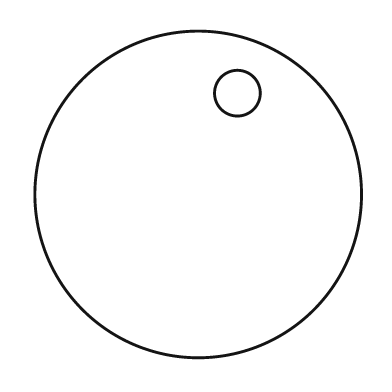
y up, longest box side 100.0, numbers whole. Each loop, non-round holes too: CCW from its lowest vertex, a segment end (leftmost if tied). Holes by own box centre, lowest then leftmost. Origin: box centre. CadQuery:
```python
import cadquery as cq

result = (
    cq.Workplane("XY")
    .moveTo(0.0, 0.0)
    .circle(50.0)
    .moveTo(12.0, 31.0)
    .circle(7.0)
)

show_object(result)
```